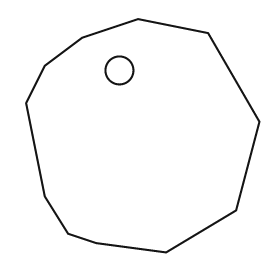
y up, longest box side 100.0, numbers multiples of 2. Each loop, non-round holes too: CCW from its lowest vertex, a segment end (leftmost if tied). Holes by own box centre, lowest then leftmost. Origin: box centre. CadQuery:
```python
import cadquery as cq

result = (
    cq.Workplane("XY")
    .moveTo(10.0, -50.0)
    .lineTo(40.0, -32.0)
    .lineTo(50.0, 6.0)
    .lineTo(28.0, 44.0)
    .lineTo(-2.0, 50.0)
    .lineTo(-26.0, 42.0)
    .lineTo(-42.0, 30.0)
    .lineTo(-50.0, 14.0)
    .lineTo(-42.0, -26.0)
    .lineTo(-32.0, -42.0)
    .lineTo(-20.0, -46.0)
    .close()
    .moveTo(-10.0, 28.0)
    .circle(6.0)
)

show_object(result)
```